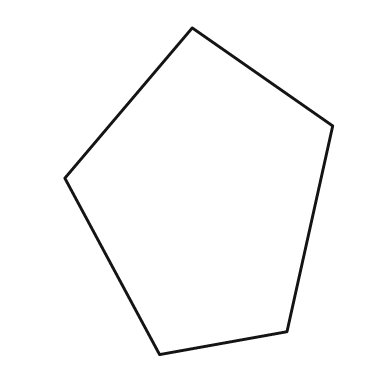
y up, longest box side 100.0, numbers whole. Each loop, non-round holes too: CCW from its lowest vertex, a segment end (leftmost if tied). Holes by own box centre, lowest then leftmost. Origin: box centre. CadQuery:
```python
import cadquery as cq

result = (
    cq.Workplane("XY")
    .moveTo(-12.0, -50.0)
    .lineTo(27.0, -43.0)
    .lineTo(41.0, 20.0)
    .lineTo(-2.0, 50.0)
    .lineTo(-41.0, 4.0)
    .close()
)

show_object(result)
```